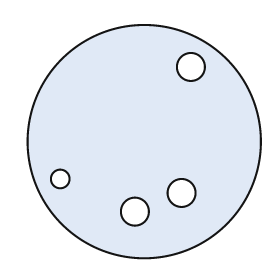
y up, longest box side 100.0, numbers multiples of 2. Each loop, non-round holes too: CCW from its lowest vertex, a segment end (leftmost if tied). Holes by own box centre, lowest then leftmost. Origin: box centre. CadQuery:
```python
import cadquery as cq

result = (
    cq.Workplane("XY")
    .moveTo(0.0, 0.0)
    .circle(50.0)
    .moveTo(-4.0, -30.0)
    .circle(6.0)
    .moveTo(16.0, -22.0)
    .circle(6.0)
    .moveTo(-36.0, -16.0)
    .circle(4.0)
    .moveTo(20.0, 32.0)
    .circle(6.0)
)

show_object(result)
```